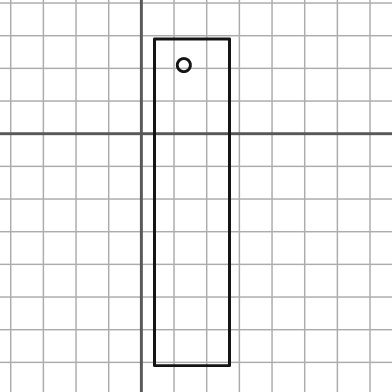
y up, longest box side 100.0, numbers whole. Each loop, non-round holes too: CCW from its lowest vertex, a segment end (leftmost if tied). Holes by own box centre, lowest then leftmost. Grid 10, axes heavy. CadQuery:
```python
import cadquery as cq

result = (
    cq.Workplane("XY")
    .moveTo(4.0, -71.0)
    .lineTo(27.0, -71.0)
    .lineTo(27.0, 29.0)
    .lineTo(4.0, 29.0)
    .close()
    .moveTo(13.0, 21.0)
    .circle(2.0)
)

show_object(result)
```